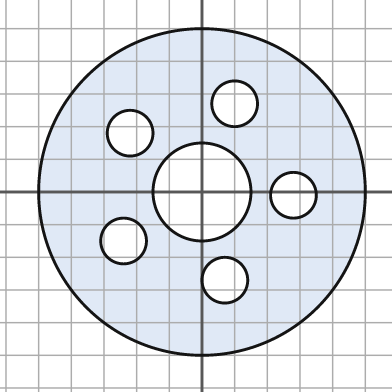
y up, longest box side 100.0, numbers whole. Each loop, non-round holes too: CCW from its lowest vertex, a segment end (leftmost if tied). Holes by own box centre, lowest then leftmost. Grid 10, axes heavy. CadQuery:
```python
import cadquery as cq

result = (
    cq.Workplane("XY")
    .moveTo(0.0, 0.0)
    .circle(50.0)
    .moveTo(7.0, -27.0)
    .circle(7.0)
    .moveTo(-24.0, -15.0)
    .circle(7.0)
    .moveTo(28.0, -1.0)
    .circle(7.0)
    .moveTo(0.0, 0.0)
    .circle(15.0)
    .moveTo(-22.0, 18.0)
    .circle(7.0)
    .moveTo(10.0, 27.0)
    .circle(7.0)
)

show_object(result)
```